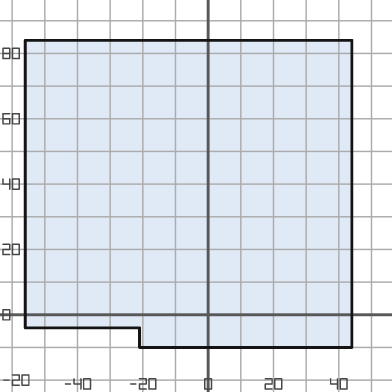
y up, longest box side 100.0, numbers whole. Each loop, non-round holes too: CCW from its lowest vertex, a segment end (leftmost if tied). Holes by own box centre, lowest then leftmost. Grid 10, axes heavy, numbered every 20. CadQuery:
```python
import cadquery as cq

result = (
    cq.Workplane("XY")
    .moveTo(-21.0, -10.0)
    .lineTo(44.0, -10.0)
    .lineTo(44.0, 84.0)
    .lineTo(-56.0, 84.0)
    .lineTo(-56.0, -4.0)
    .lineTo(-21.0, -4.0)
    .close()
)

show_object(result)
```